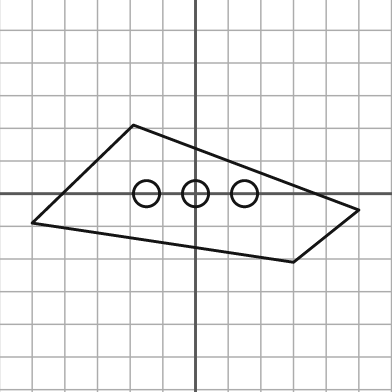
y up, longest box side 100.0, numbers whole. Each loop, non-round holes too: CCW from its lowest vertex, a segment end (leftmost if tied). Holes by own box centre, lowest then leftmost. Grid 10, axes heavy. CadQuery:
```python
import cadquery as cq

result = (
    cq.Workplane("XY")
    .moveTo(30.0, -21.0)
    .lineTo(50.0, -5.0)
    .lineTo(-19.0, 21.0)
    .lineTo(-50.0, -9.0)
    .close()
    .moveTo(-15.0, 0.0)
    .circle(4.0)
    .moveTo(0.0, 0.0)
    .circle(4.0)
    .moveTo(15.0, 0.0)
    .circle(4.0)
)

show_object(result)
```